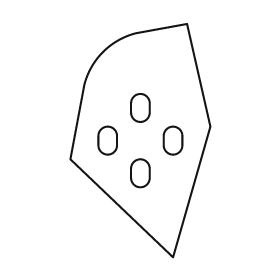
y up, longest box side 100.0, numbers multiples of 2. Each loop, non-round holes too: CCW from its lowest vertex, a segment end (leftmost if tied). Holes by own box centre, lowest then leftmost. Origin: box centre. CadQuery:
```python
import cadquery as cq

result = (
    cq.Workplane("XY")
    .moveTo(14.0, -50.0)
    .lineTo(30.0, 6.0)
    .lineTo(20.0, 50.0)
    .lineTo(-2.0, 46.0)
    .threePointArc((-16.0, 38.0), (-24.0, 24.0))
    .lineTo(-30.0, -8.0)
    .close()
    .moveTo(-4.0, -16.0)
    .threePointArc((0.0, -20.0), (4.0, -16.0))
    .lineTo(4.0, -12.0)
    .threePointArc((0.0, -8.0), (-4.0, -12.0))
    .close()
    .moveTo(-18.0, -2.0)
    .threePointArc((-14.0, -6.0), (-10.0, -2.0))
    .lineTo(-10.0, 2.0)
    .threePointArc((-14.0, 6.0), (-18.0, 2.0))
    .close()
    .moveTo(10.0, -2.0)
    .threePointArc((14.0, -6.0), (18.0, -2.0))
    .lineTo(18.0, 2.0)
    .threePointArc((14.0, 6.0), (10.0, 2.0))
    .close()
    .moveTo(-4.0, 12.0)
    .threePointArc((0.0, 8.0), (4.0, 12.0))
    .lineTo(4.0, 16.0)
    .threePointArc((0.0, 20.0), (-4.0, 16.0))
    .close()
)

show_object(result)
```